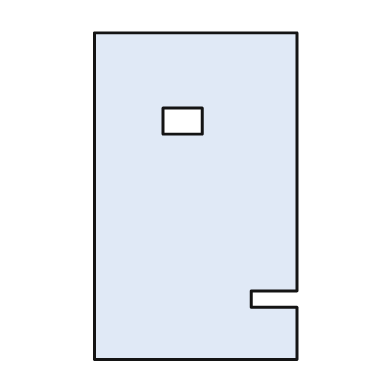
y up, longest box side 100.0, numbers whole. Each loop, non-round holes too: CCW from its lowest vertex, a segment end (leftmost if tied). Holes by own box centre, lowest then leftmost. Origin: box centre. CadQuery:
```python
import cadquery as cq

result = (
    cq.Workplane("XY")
    .moveTo(-31.0, -50.0)
    .lineTo(31.0, -50.0)
    .lineTo(31.0, -34.0)
    .lineTo(17.0, -34.0)
    .lineTo(17.0, -29.0)
    .lineTo(31.0, -29.0)
    .lineTo(31.0, 50.0)
    .lineTo(-31.0, 50.0)
    .close()
    .moveTo(-10.0, 19.0)
    .lineTo(2.0, 19.0)
    .lineTo(2.0, 27.0)
    .lineTo(-10.0, 27.0)
    .close()
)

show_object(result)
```